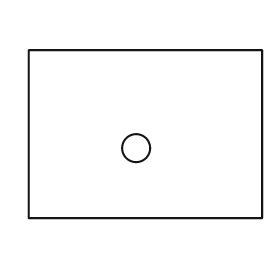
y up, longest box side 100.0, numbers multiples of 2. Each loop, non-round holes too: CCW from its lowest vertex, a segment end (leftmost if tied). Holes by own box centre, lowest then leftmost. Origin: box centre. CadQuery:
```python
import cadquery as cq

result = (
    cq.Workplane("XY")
    .moveTo(-50.0, -36.0)
    .lineTo(50.0, -36.0)
    .lineTo(50.0, 36.0)
    .lineTo(-50.0, 36.0)
    .close()
    .moveTo(-4.0, -6.0)
    .circle(6.0)
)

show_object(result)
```